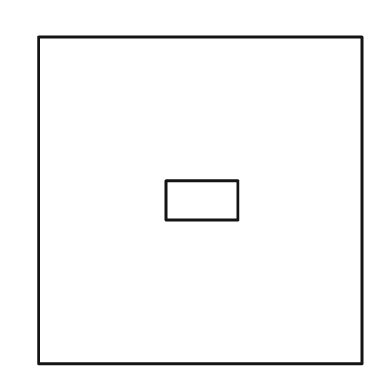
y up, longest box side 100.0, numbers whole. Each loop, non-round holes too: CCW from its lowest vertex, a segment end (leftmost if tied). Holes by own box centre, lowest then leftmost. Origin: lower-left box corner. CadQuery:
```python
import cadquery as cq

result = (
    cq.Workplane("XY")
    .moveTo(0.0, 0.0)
    .lineTo(99.0, 0.0)
    .lineTo(99.0, 100.0)
    .lineTo(0.0, 100.0)
    .close()
    .moveTo(39.0, 44.0)
    .lineTo(61.0, 44.0)
    .lineTo(61.0, 56.0)
    .lineTo(39.0, 56.0)
    .close()
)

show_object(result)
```